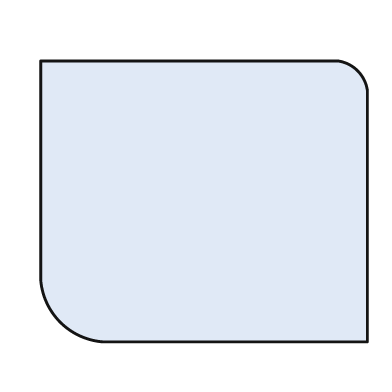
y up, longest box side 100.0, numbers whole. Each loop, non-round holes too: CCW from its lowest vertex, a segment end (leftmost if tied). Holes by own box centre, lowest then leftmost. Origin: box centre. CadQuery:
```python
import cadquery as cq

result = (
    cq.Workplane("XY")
    .moveTo(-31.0, -43.0)
    .lineTo(50.0, -43.0)
    .lineTo(50.0, 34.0)
    .threePointArc((47.0, 40.0), (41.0, 43.0))
    .lineTo(-50.0, 43.0)
    .lineTo(-50.0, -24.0)
    .threePointArc((-44.0, -37.0), (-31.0, -43.0))
    .close()
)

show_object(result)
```